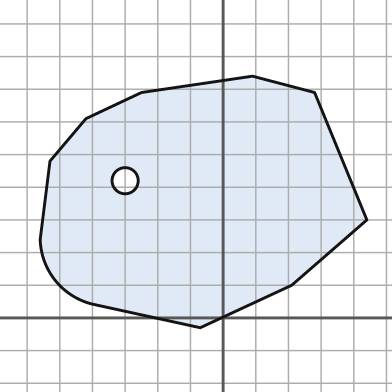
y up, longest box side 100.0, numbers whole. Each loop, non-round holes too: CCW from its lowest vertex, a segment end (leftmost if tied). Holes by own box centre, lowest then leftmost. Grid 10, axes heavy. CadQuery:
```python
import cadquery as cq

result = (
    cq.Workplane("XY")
    .moveTo(-7.0, -3.0)
    .lineTo(21.0, 10.0)
    .lineTo(44.0, 30.0)
    .lineTo(28.0, 69.0)
    .lineTo(9.0, 74.0)
    .lineTo(-25.0, 69.0)
    .lineTo(-42.0, 61.0)
    .lineTo(-53.0, 48.0)
    .lineTo(-56.0, 24.0)
    .threePointArc((-51.0, 11.0), (-39.0, 4.0))
    .close()
    .moveTo(-30.0, 42.0)
    .circle(4.0)
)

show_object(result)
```